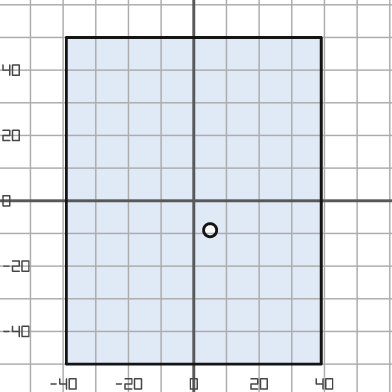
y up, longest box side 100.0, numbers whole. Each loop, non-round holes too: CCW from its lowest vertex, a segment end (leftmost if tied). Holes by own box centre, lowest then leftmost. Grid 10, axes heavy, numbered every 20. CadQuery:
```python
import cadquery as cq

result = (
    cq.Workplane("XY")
    .moveTo(-39.0, -50.0)
    .lineTo(39.0, -50.0)
    .lineTo(39.0, 50.0)
    .lineTo(-39.0, 50.0)
    .close()
    .moveTo(5.0, -9.0)
    .circle(2.0)
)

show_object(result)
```